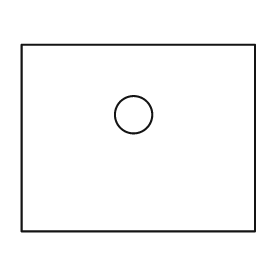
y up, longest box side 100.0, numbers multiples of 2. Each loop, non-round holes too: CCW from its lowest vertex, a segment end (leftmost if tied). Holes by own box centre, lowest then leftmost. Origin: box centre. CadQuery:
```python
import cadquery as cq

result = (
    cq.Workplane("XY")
    .moveTo(-50.0, -40.0)
    .lineTo(50.0, -40.0)
    .lineTo(50.0, 40.0)
    .lineTo(-50.0, 40.0)
    .close()
    .moveTo(-2.0, 10.0)
    .circle(8.0)
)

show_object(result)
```